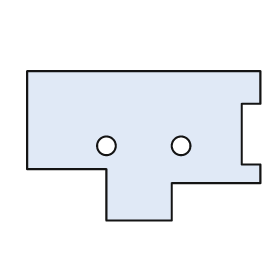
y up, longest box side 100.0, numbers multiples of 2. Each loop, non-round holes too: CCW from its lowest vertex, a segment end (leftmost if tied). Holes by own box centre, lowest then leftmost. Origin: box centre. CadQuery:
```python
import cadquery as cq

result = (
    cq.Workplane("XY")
    .moveTo(-16.0, -32.0)
    .lineTo(12.0, -32.0)
    .lineTo(12.0, -16.0)
    .lineTo(50.0, -16.0)
    .lineTo(50.0, -8.0)
    .lineTo(42.0, -8.0)
    .lineTo(42.0, 18.0)
    .lineTo(50.0, 18.0)
    .lineTo(50.0, 32.0)
    .lineTo(-50.0, 32.0)
    .lineTo(-50.0, -10.0)
    .lineTo(-16.0, -10.0)
    .close()
    .moveTo(-16.0, 0.0)
    .circle(4.0)
    .moveTo(16.0, 0.0)
    .circle(4.0)
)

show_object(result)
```